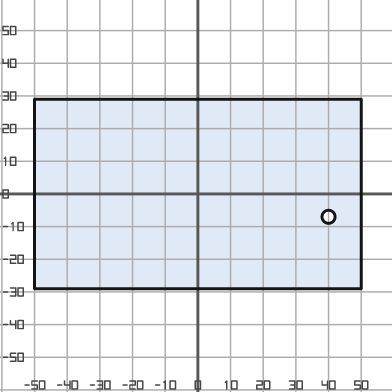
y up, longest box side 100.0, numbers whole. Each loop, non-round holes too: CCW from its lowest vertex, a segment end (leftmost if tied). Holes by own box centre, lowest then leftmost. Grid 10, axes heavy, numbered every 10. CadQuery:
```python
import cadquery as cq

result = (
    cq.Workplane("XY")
    .moveTo(-50.0, -29.0)
    .lineTo(50.0, -29.0)
    .lineTo(50.0, 29.0)
    .lineTo(-50.0, 29.0)
    .close()
    .moveTo(40.0, -7.0)
    .circle(2.0)
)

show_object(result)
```